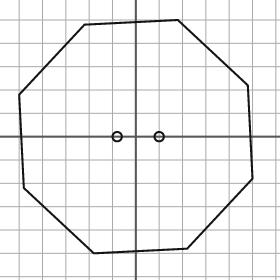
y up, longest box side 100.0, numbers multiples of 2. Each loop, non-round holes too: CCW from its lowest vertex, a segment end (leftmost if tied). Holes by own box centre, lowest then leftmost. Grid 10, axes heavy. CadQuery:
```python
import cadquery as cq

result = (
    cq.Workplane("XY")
    .moveTo(-18.0, -50.0)
    .lineTo(22.0, -48.0)
    .lineTo(50.0, -18.0)
    .lineTo(48.0, 22.0)
    .lineTo(18.0, 50.0)
    .lineTo(-22.0, 48.0)
    .lineTo(-50.0, 18.0)
    .lineTo(-48.0, -22.0)
    .close()
    .moveTo(-8.0, 0.0)
    .circle(2.0)
    .moveTo(10.0, 0.0)
    .circle(2.0)
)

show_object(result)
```